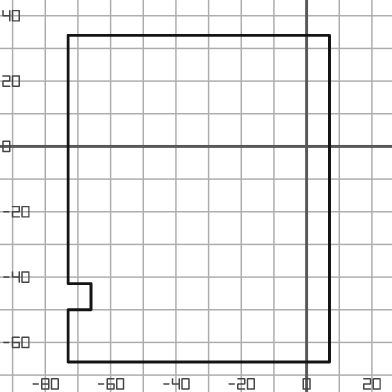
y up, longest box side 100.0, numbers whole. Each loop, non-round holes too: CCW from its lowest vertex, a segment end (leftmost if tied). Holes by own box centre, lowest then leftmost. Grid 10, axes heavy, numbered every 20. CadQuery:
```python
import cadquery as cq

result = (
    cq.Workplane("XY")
    .moveTo(-73.0, -66.0)
    .lineTo(7.0, -66.0)
    .lineTo(7.0, 34.0)
    .lineTo(-73.0, 34.0)
    .lineTo(-73.0, -42.0)
    .lineTo(-66.0, -42.0)
    .lineTo(-66.0, -50.0)
    .lineTo(-73.0, -50.0)
    .close()
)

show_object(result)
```